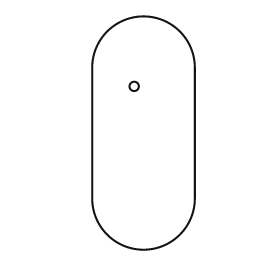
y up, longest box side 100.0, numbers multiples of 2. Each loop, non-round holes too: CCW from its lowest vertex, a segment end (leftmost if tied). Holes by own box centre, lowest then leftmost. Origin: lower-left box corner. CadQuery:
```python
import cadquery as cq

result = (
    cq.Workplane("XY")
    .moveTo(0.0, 22.0)
    .threePointArc((22.0, 0.0), (44.0, 22.0))
    .lineTo(44.0, 78.0)
    .threePointArc((22.0, 100.0), (0.0, 78.0))
    .close()
    .moveTo(18.0, 70.0)
    .circle(2.0)
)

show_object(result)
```